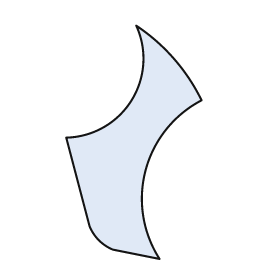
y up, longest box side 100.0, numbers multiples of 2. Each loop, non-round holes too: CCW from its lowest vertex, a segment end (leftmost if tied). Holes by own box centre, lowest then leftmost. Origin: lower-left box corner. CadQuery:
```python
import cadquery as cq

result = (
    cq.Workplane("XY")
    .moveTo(40.0, 0.0)
    .threePointArc((34.0, 38.0), (58.0, 68.0))
    .threePointArc((46.0, 86.0), (30.0, 100.0))
    .threePointArc((28.0, 68.0), (0.0, 52.0))
    .lineTo(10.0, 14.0)
    .threePointArc((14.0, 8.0), (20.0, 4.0))
    .close()
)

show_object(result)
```